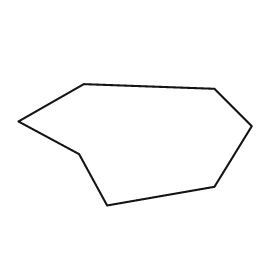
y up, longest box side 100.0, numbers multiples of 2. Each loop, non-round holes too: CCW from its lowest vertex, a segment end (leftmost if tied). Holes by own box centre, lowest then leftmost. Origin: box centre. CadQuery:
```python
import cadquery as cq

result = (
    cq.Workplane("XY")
    .moveTo(-12.0, -26.0)
    .lineTo(34.0, -18.0)
    .lineTo(50.0, 8.0)
    .lineTo(34.0, 24.0)
    .lineTo(-22.0, 26.0)
    .lineTo(-50.0, 10.0)
    .lineTo(-24.0, -4.0)
    .close()
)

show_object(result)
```